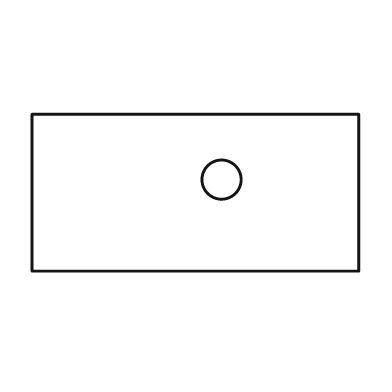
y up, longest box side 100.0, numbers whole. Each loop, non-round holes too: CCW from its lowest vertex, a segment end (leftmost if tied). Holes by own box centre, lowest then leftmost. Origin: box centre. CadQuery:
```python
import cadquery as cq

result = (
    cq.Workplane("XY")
    .moveTo(-50.0, -24.0)
    .lineTo(50.0, -24.0)
    .lineTo(50.0, 24.0)
    .lineTo(-50.0, 24.0)
    .close()
    .moveTo(8.0, 4.0)
    .circle(6.0)
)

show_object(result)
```